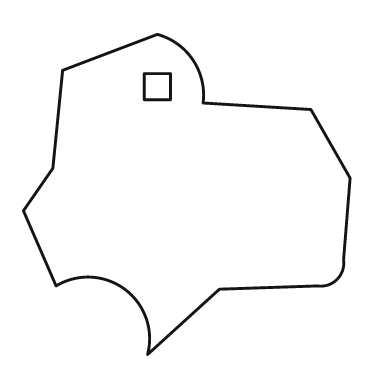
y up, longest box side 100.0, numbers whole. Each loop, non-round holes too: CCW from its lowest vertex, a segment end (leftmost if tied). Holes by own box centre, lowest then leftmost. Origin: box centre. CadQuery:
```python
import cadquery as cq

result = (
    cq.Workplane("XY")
    .moveTo(-12.0, -49.0)
    .lineTo(10.0, -29.0)
    .lineTo(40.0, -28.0)
    .threePointArc((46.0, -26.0), (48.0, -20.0))
    .lineTo(50.0, 5.0)
    .lineTo(38.0, 26.0)
    .lineTo(5.0, 28.0)
    .threePointArc((2.0, 41.0), (-9.0, 49.0))
    .lineTo(-38.0, 38.0)
    .lineTo(-41.0, 8.0)
    .lineTo(-50.0, -5.0)
    .lineTo(-40.0, -28.0)
    .threePointArc((-19.0, -29.0), (-12.0, -49.0))
    .close()
    .moveTo(-13.0, 29.0)
    .lineTo(-5.0, 29.0)
    .lineTo(-5.0, 37.0)
    .lineTo(-13.0, 37.0)
    .close()
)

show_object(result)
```